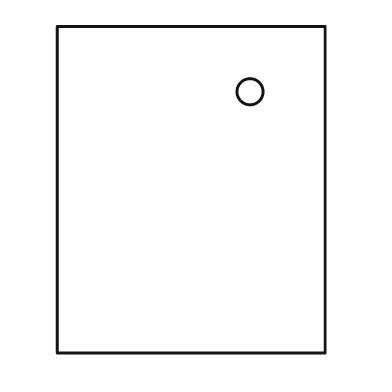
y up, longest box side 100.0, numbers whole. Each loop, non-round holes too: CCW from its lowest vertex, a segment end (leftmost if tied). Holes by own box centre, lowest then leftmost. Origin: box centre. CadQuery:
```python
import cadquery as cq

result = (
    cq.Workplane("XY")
    .moveTo(-41.0, -50.0)
    .lineTo(41.0, -50.0)
    .lineTo(41.0, 50.0)
    .lineTo(-41.0, 50.0)
    .close()
    .moveTo(18.0, 30.0)
    .circle(4.0)
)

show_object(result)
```